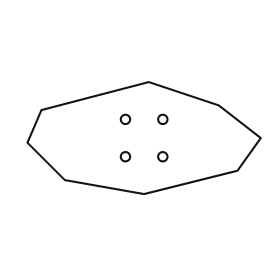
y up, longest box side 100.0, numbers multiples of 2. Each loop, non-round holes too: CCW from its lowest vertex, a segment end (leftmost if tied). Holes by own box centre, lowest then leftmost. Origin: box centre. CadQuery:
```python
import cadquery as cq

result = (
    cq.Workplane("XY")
    .moveTo(0.0, -24.0)
    .lineTo(40.0, -14.0)
    .lineTo(50.0, 0.0)
    .lineTo(32.0, 14.0)
    .lineTo(2.0, 24.0)
    .lineTo(-44.0, 12.0)
    .lineTo(-50.0, -2.0)
    .lineTo(-34.0, -18.0)
    .close()
    .moveTo(-8.0, -8.0)
    .circle(2.0)
    .moveTo(8.0, -8.0)
    .circle(2.0)
    .moveTo(-8.0, 8.0)
    .circle(2.0)
    .moveTo(8.0, 8.0)
    .circle(2.0)
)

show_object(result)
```